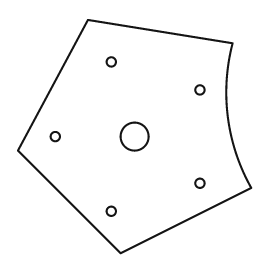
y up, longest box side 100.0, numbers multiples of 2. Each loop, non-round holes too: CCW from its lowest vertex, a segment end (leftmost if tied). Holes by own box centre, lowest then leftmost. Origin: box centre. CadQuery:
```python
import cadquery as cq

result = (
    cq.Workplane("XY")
    .moveTo(-6.0, -50.0)
    .lineTo(50.0, -22.0)
    .threePointArc((40.0, 8.0), (42.0, 40.0))
    .lineTo(-20.0, 50.0)
    .lineTo(-50.0, -6.0)
    .close()
    .moveTo(-10.0, -32.0)
    .circle(2.0)
    .moveTo(28.0, -20.0)
    .circle(2.0)
    .moveTo(-34.0, 0.0)
    .circle(2.0)
    .moveTo(0.0, 0.0)
    .circle(6.0)
    .moveTo(28.0, 20.0)
    .circle(2.0)
    .moveTo(-10.0, 32.0)
    .circle(2.0)
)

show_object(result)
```